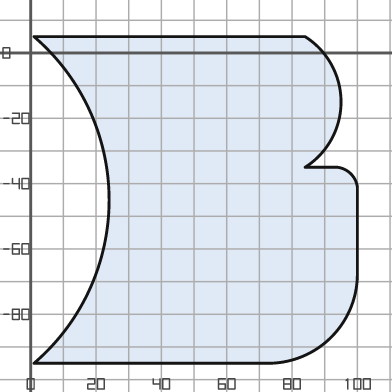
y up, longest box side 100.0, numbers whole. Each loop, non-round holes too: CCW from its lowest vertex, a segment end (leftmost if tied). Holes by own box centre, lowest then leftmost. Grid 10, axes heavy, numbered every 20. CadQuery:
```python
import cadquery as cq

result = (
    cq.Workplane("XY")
    .moveTo(1.0, -95.0)
    .lineTo(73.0, -95.0)
    .threePointArc((92.0, -87.0), (100.0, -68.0))
    .lineTo(100.0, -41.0)
    .threePointArc((98.0, -37.0), (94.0, -35.0))
    .lineTo(84.0, -35.0)
    .threePointArc((95.0, -15.0), (84.0, 5.0))
    .lineTo(1.0, 5.0)
    .threePointArc((24.0, -45.0), (1.0, -95.0))
    .close()
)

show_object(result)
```